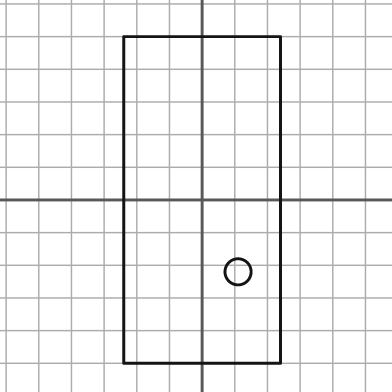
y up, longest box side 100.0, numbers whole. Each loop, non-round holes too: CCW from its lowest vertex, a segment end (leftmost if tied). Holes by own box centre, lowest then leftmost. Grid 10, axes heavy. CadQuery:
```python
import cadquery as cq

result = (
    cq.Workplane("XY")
    .moveTo(-24.0, -50.0)
    .lineTo(24.0, -50.0)
    .lineTo(24.0, 50.0)
    .lineTo(-24.0, 50.0)
    .close()
    .moveTo(11.0, -22.0)
    .circle(4.0)
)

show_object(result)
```